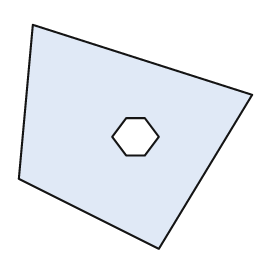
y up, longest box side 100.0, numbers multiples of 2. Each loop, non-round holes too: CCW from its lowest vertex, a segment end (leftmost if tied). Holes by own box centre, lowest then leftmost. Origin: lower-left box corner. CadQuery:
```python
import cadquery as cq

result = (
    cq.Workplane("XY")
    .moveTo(60.0, 0.0)
    .lineTo(100.0, 66.0)
    .lineTo(6.0, 96.0)
    .lineTo(0.0, 30.0)
    .close()
    .moveTo(46.0, 40.0)
    .lineTo(54.0, 40.0)
    .lineTo(60.0, 48.0)
    .lineTo(54.0, 56.0)
    .lineTo(46.0, 56.0)
    .lineTo(40.0, 48.0)
    .close()
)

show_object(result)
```